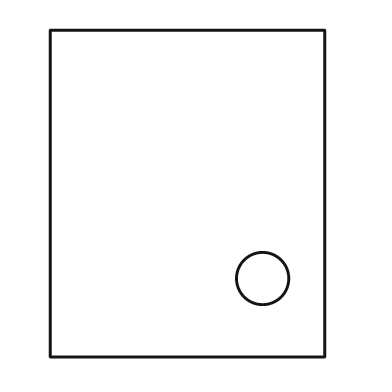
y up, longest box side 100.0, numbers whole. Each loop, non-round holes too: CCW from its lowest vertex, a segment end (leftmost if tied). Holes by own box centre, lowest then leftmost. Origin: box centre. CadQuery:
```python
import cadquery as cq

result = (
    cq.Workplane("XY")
    .moveTo(-42.0, -50.0)
    .lineTo(42.0, -50.0)
    .lineTo(42.0, 50.0)
    .lineTo(-42.0, 50.0)
    .close()
    .moveTo(23.0, -26.0)
    .circle(8.0)
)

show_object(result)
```